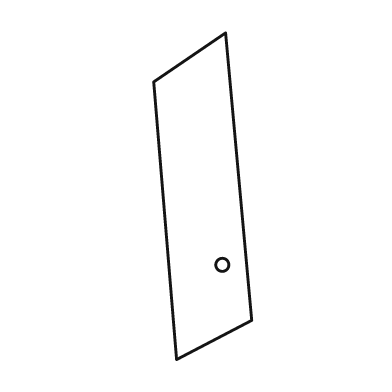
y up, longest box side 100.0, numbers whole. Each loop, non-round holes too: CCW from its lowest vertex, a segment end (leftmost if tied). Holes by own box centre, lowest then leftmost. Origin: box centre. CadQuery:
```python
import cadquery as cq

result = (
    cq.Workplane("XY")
    .moveTo(-8.0, -50.0)
    .lineTo(15.0, -38.0)
    .lineTo(7.0, 50.0)
    .lineTo(-15.0, 35.0)
    .close()
    .moveTo(6.0, -21.0)
    .circle(2.0)
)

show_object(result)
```